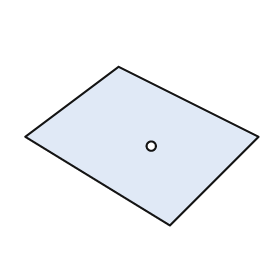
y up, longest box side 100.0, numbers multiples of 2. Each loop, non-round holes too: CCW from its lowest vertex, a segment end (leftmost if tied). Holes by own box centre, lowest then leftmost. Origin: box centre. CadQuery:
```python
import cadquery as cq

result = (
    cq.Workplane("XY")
    .moveTo(12.0, -34.0)
    .lineTo(50.0, 4.0)
    .lineTo(-10.0, 34.0)
    .lineTo(-50.0, 4.0)
    .close()
    .moveTo(4.0, 0.0)
    .circle(2.0)
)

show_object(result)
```